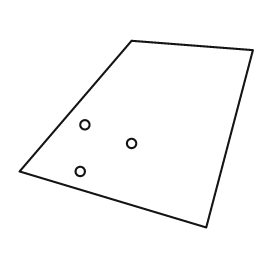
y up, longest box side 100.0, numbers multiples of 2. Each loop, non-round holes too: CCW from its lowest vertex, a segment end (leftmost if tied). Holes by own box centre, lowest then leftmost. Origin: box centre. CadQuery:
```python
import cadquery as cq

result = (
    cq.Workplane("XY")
    .moveTo(30.0, -40.0)
    .lineTo(50.0, 36.0)
    .lineTo(-2.0, 40.0)
    .lineTo(-50.0, -16.0)
    .close()
    .moveTo(-24.0, -16.0)
    .circle(2.0)
    .moveTo(-2.0, -4.0)
    .circle(2.0)
    .moveTo(-22.0, 4.0)
    .circle(2.0)
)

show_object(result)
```